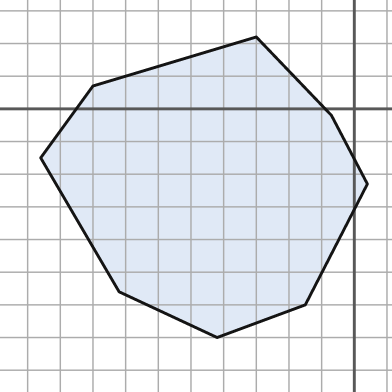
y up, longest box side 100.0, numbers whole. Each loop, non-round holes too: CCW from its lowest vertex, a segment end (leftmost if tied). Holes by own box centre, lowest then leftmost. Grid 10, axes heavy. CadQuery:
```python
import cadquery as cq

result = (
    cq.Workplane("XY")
    .moveTo(-42.0, -70.0)
    .lineTo(-15.0, -60.0)
    .lineTo(4.0, -23.0)
    .lineTo(-7.0, -2.0)
    .lineTo(-30.0, 22.0)
    .lineTo(-80.0, 7.0)
    .lineTo(-96.0, -15.0)
    .lineTo(-72.0, -56.0)
    .close()
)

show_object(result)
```